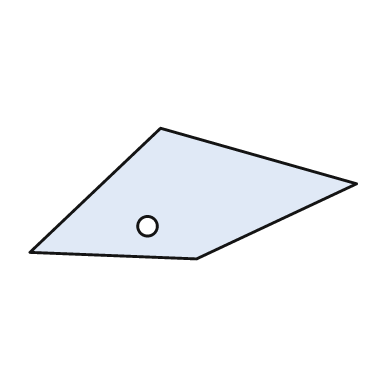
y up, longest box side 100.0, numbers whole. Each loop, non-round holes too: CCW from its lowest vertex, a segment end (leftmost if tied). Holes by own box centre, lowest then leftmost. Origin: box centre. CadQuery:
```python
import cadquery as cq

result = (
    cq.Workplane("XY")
    .moveTo(1.0, -20.0)
    .lineTo(50.0, 3.0)
    .lineTo(-10.0, 20.0)
    .lineTo(-50.0, -18.0)
    .close()
    .moveTo(-14.0, -10.0)
    .circle(3.0)
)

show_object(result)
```